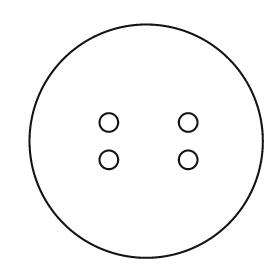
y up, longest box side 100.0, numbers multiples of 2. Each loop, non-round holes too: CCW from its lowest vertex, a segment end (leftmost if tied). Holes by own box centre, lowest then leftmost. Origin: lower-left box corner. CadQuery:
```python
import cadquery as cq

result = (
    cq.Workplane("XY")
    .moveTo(50.0, 50.0)
    .circle(50.0)
    .moveTo(34.0, 42.0)
    .circle(4.0)
    .moveTo(68.0, 42.0)
    .circle(4.0)
    .moveTo(34.0, 58.0)
    .circle(4.0)
    .moveTo(68.0, 58.0)
    .circle(4.0)
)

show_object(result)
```